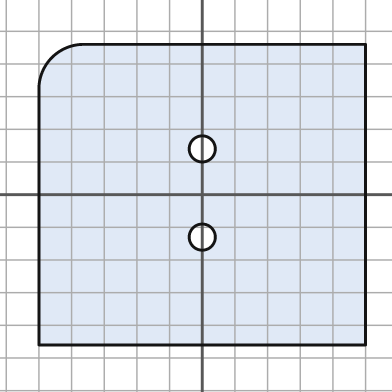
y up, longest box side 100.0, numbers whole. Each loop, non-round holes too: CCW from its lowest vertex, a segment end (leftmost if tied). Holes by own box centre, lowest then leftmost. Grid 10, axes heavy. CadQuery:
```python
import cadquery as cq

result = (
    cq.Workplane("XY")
    .moveTo(-50.0, -46.0)
    .lineTo(50.0, -46.0)
    .lineTo(50.0, 46.0)
    .lineTo(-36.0, 46.0)
    .threePointArc((-46.0, 42.0), (-50.0, 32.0))
    .close()
    .moveTo(0.0, -13.0)
    .circle(4.0)
    .moveTo(0.0, 14.0)
    .circle(4.0)
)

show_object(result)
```